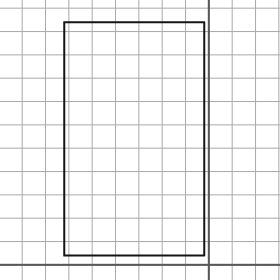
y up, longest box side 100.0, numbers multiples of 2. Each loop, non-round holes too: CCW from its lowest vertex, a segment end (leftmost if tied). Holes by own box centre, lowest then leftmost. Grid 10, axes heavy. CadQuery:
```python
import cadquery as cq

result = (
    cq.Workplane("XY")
    .moveTo(-62.0, 4.0)
    .lineTo(-2.0, 4.0)
    .lineTo(-2.0, 104.0)
    .lineTo(-62.0, 104.0)
    .close()
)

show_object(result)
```